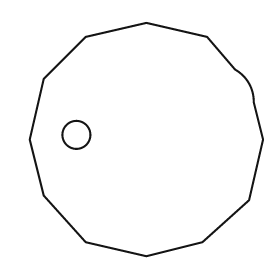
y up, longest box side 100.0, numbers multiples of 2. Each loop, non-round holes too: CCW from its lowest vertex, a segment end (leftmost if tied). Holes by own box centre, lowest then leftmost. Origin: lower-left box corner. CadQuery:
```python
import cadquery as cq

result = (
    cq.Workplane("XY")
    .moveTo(50.0, 0.0)
    .lineTo(74.0, 6.0)
    .lineTo(94.0, 24.0)
    .lineTo(100.0, 50.0)
    .lineTo(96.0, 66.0)
    .threePointArc((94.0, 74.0), (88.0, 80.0))
    .lineTo(76.0, 94.0)
    .lineTo(50.0, 100.0)
    .lineTo(24.0, 94.0)
    .lineTo(6.0, 76.0)
    .lineTo(0.0, 50.0)
    .lineTo(6.0, 26.0)
    .lineTo(24.0, 6.0)
    .close()
    .moveTo(20.0, 52.0)
    .circle(6.0)
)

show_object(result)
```